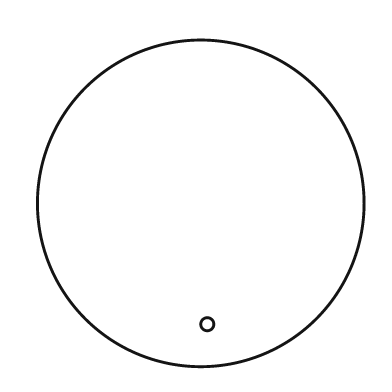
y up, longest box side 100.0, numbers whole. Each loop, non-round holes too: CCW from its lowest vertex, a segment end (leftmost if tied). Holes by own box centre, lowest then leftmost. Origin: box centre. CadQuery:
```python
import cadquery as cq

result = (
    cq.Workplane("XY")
    .moveTo(0.0, 0.0)
    .circle(50.0)
    .moveTo(2.0, -37.0)
    .circle(2.0)
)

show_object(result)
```